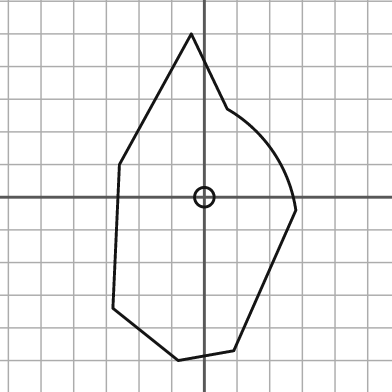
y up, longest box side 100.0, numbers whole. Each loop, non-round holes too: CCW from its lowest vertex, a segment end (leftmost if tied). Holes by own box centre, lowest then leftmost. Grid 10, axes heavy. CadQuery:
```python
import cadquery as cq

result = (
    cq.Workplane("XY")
    .moveTo(-8.0, -50.0)
    .lineTo(9.0, -47.0)
    .lineTo(28.0, -4.0)
    .threePointArc((21.0, 14.0), (7.0, 27.0))
    .lineTo(-4.0, 50.0)
    .lineTo(-26.0, 10.0)
    .lineTo(-28.0, -34.0)
    .close()
    .moveTo(0.0, 0.0)
    .circle(3.0)
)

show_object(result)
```